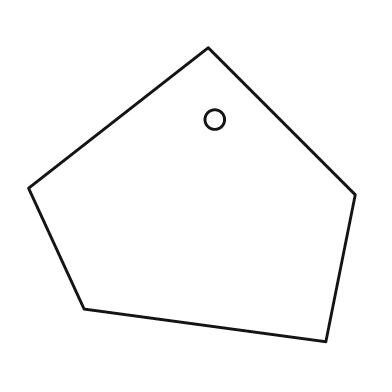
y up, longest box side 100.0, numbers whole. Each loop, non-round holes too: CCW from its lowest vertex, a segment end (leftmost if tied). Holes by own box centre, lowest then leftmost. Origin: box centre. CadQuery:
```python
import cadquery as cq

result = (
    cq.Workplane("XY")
    .moveTo(41.0, -45.0)
    .lineTo(50.0, 0.0)
    .lineTo(5.0, 45.0)
    .lineTo(-50.0, 2.0)
    .lineTo(-33.0, -35.0)
    .close()
    .moveTo(7.0, 23.0)
    .circle(3.0)
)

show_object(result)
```